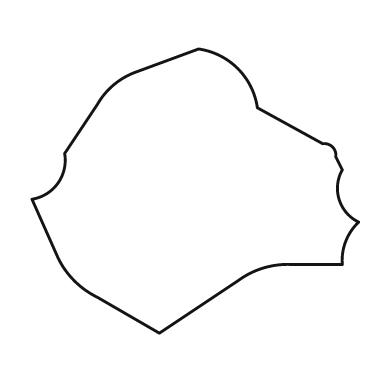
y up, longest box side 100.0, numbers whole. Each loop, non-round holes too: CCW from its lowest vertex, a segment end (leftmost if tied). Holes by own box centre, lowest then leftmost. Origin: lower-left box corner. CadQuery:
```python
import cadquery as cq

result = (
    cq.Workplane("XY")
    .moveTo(39.0, 0.0)
    .lineTo(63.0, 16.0)
    .threePointArc((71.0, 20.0), (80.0, 21.0))
    .lineTo(95.0, 21.0)
    .threePointArc((96.0, 28.0), (100.0, 34.0))
    .threePointArc((94.0, 41.0), (95.0, 50.0))
    .lineTo(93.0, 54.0)
    .threePointArc((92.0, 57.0), (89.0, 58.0))
    .lineTo(69.0, 69.0)
    .threePointArc((63.0, 81.0), (51.0, 87.0))
    .lineTo(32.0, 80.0)
    .threePointArc((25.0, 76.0), (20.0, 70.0))
    .lineTo(10.0, 55.0)
    .threePointArc((8.0, 46.0), (0.0, 41.0))
    .lineTo(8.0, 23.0)
    .threePointArc((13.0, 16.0), (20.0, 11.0))
    .close()
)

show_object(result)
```